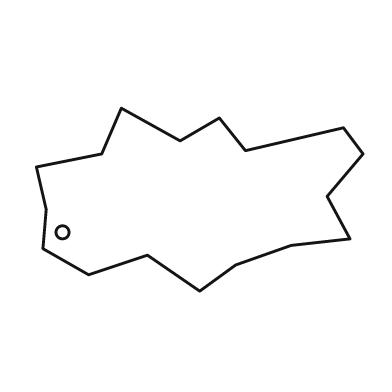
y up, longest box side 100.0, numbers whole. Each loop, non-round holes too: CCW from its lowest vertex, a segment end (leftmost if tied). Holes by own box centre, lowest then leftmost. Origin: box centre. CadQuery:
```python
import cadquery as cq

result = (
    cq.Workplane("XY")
    .moveTo(0.0, -28.0)
    .lineTo(11.0, -20.0)
    .lineTo(28.0, -14.0)
    .lineTo(46.0, -12.0)
    .lineTo(39.0, 1.0)
    .lineTo(50.0, 14.0)
    .lineTo(44.0, 22.0)
    .lineTo(14.0, 15.0)
    .lineTo(6.0, 25.0)
    .lineTo(-6.0, 18.0)
    .lineTo(-24.0, 28.0)
    .lineTo(-30.0, 14.0)
    .lineTo(-50.0, 10.0)
    .lineTo(-47.0, -3.0)
    .lineTo(-48.0, -15.0)
    .lineTo(-34.0, -23.0)
    .lineTo(-16.0, -17.0)
    .close()
    .moveTo(-42.0, -10.0)
    .circle(2.0)
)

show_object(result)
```